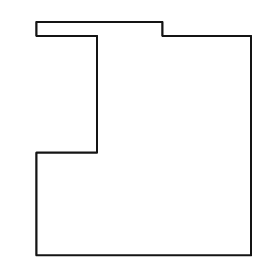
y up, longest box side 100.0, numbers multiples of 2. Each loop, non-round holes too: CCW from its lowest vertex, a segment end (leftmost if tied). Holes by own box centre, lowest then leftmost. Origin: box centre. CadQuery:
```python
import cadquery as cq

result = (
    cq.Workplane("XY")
    .moveTo(-46.0, -50.0)
    .lineTo(46.0, -50.0)
    .lineTo(46.0, 44.0)
    .lineTo(8.0, 44.0)
    .lineTo(8.0, 50.0)
    .lineTo(-46.0, 50.0)
    .lineTo(-46.0, 44.0)
    .lineTo(-20.0, 44.0)
    .lineTo(-20.0, -6.0)
    .lineTo(-46.0, -6.0)
    .close()
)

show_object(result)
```